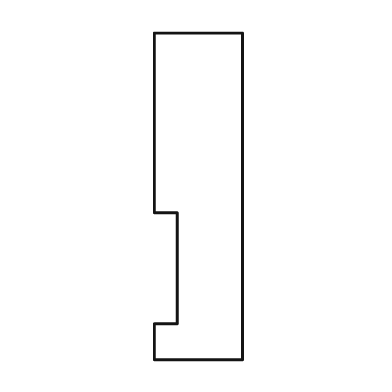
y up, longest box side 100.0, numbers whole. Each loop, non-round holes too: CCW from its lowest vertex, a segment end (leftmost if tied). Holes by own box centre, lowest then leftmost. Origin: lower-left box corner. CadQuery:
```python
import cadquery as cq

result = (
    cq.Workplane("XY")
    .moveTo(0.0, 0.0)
    .lineTo(27.0, 0.0)
    .lineTo(27.0, 100.0)
    .lineTo(0.0, 100.0)
    .lineTo(0.0, 45.0)
    .lineTo(7.0, 45.0)
    .lineTo(7.0, 11.0)
    .lineTo(0.0, 11.0)
    .close()
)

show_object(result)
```